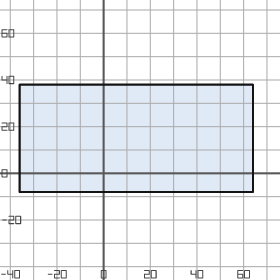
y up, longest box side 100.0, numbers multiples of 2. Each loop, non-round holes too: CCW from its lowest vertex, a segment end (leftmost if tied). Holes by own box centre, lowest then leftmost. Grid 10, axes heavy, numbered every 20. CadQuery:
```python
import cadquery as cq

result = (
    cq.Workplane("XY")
    .moveTo(-36.0, -8.0)
    .lineTo(64.0, -8.0)
    .lineTo(64.0, 38.0)
    .lineTo(-36.0, 38.0)
    .close()
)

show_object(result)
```